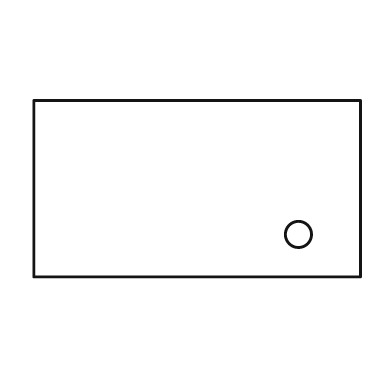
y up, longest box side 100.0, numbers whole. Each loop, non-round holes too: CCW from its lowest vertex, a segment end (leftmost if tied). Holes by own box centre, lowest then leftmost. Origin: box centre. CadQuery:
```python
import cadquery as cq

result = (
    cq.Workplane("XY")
    .moveTo(-50.0, -27.0)
    .lineTo(50.0, -27.0)
    .lineTo(50.0, 27.0)
    .lineTo(-50.0, 27.0)
    .close()
    .moveTo(31.0, -14.0)
    .circle(4.0)
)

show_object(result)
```